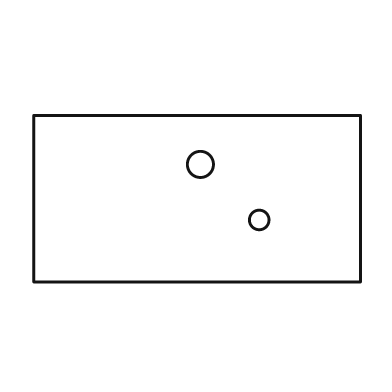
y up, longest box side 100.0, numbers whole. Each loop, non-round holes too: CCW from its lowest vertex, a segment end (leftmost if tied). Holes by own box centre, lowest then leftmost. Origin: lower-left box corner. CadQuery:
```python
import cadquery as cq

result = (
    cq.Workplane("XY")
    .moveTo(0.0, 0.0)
    .lineTo(100.0, 0.0)
    .lineTo(100.0, 51.0)
    .lineTo(0.0, 51.0)
    .close()
    .moveTo(69.0, 19.0)
    .circle(3.0)
    .moveTo(51.0, 36.0)
    .circle(4.0)
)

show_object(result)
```